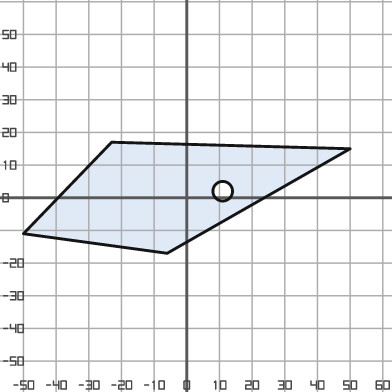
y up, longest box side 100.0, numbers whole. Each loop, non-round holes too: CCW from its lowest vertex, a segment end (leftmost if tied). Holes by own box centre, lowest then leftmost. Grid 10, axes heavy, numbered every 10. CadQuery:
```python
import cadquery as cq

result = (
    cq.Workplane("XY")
    .moveTo(-6.0, -17.0)
    .lineTo(50.0, 15.0)
    .lineTo(-23.0, 17.0)
    .lineTo(-50.0, -11.0)
    .close()
    .moveTo(11.0, 2.0)
    .circle(3.0)
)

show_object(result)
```